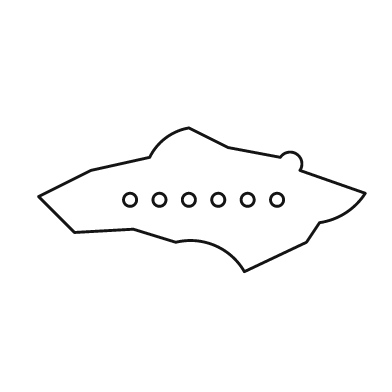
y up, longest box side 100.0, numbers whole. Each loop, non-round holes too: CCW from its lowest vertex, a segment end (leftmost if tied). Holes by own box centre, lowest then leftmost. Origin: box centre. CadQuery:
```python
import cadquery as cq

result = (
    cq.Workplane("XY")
    .moveTo(13.0, -22.0)
    .lineTo(32.0, -13.0)
    .lineTo(36.0, -7.0)
    .threePointArc((44.0, -4.0), (50.0, 2.0))
    .lineTo(30.0, 9.0)
    .threePointArc((29.0, 14.0), (24.0, 13.0))
    .lineTo(8.0, 16.0)
    .lineTo(-4.0, 22.0)
    .threePointArc((-11.0, 19.0), (-16.0, 13.0))
    .lineTo(-34.0, 9.0)
    .lineTo(-50.0, 1.0)
    .lineTo(-39.0, -10.0)
    .lineTo(-21.0, -9.0)
    .lineTo(-8.0, -13.0)
    .threePointArc((4.0, -14.0), (13.0, -22.0))
    .close()
    .moveTo(-22.0, 0.0)
    .circle(2.0)
    .moveTo(-13.0, 0.0)
    .circle(2.0)
    .moveTo(-4.0, 0.0)
    .circle(2.0)
    .moveTo(5.0, 0.0)
    .circle(2.0)
    .moveTo(14.0, 0.0)
    .circle(2.0)
    .moveTo(23.0, 0.0)
    .circle(2.0)
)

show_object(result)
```